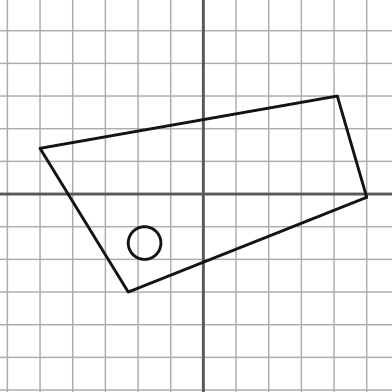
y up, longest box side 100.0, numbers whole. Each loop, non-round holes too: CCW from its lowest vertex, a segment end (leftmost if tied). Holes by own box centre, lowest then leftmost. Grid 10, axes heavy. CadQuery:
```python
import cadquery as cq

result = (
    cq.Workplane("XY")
    .moveTo(-23.0, -30.0)
    .lineTo(50.0, -1.0)
    .lineTo(41.0, 30.0)
    .lineTo(-50.0, 14.0)
    .close()
    .moveTo(-18.0, -15.0)
    .circle(5.0)
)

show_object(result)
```